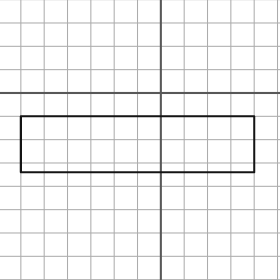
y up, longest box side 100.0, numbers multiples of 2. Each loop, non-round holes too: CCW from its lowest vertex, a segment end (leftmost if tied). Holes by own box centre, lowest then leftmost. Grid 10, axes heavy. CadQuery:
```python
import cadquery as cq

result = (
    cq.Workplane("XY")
    .moveTo(-60.0, -34.0)
    .lineTo(40.0, -34.0)
    .lineTo(40.0, -10.0)
    .lineTo(-60.0, -10.0)
    .close()
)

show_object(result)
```